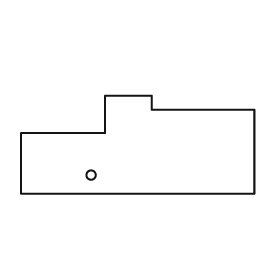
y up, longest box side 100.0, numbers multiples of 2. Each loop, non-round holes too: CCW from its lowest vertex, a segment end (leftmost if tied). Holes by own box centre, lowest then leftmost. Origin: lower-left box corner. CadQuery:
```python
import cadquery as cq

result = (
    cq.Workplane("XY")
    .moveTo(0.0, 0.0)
    .lineTo(100.0, 0.0)
    .lineTo(100.0, 36.0)
    .lineTo(56.0, 36.0)
    .lineTo(56.0, 42.0)
    .lineTo(36.0, 42.0)
    .lineTo(36.0, 26.0)
    .lineTo(0.0, 26.0)
    .close()
    .moveTo(30.0, 8.0)
    .circle(2.0)
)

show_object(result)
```